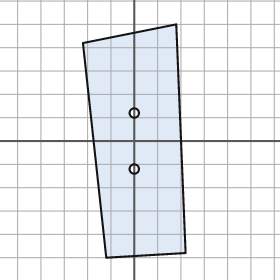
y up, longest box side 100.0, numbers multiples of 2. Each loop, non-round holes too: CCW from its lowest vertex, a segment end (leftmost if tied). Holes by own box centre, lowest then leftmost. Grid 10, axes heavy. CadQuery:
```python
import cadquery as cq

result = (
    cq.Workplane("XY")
    .moveTo(-12.0, -50.0)
    .lineTo(22.0, -48.0)
    .lineTo(18.0, 50.0)
    .lineTo(-22.0, 42.0)
    .close()
    .moveTo(0.0, -12.0)
    .circle(2.0)
    .moveTo(0.0, 12.0)
    .circle(2.0)
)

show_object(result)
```